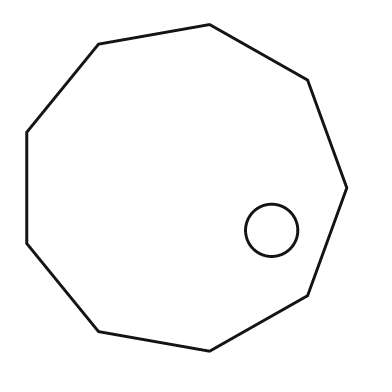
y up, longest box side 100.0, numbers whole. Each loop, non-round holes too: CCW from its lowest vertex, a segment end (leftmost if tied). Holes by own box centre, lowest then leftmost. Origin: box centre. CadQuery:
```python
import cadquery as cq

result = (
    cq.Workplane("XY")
    .moveTo(7.0, -50.0)
    .lineTo(37.0, -33.0)
    .lineTo(49.0, 0.0)
    .lineTo(37.0, 33.0)
    .lineTo(7.0, 50.0)
    .lineTo(-27.0, 44.0)
    .lineTo(-49.0, 17.0)
    .lineTo(-49.0, -17.0)
    .lineTo(-27.0, -44.0)
    .close()
    .moveTo(26.0, -13.0)
    .circle(8.0)
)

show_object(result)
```